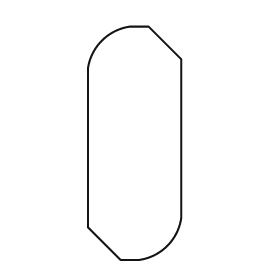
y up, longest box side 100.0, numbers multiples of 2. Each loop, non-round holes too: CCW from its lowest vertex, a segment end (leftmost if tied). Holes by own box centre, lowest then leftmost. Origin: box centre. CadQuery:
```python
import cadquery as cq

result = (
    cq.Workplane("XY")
    .moveTo(-6.0, -50.0)
    .lineTo(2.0, -50.0)
    .threePointArc((14.0, -44.0), (20.0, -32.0))
    .lineTo(20.0, 36.0)
    .lineTo(6.0, 50.0)
    .lineTo(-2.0, 50.0)
    .threePointArc((-14.0, 44.0), (-20.0, 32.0))
    .lineTo(-20.0, -36.0)
    .close()
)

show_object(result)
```